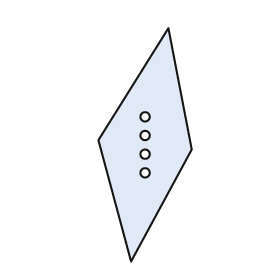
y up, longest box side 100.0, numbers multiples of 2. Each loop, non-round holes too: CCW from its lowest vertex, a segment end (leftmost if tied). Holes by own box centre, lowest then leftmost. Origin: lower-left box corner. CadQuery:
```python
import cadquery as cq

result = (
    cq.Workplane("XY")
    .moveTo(14.0, 0.0)
    .lineTo(40.0, 48.0)
    .lineTo(30.0, 100.0)
    .lineTo(0.0, 52.0)
    .close()
    .moveTo(20.0, 38.0)
    .circle(2.0)
    .moveTo(20.0, 46.0)
    .circle(2.0)
    .moveTo(20.0, 54.0)
    .circle(2.0)
    .moveTo(20.0, 62.0)
    .circle(2.0)
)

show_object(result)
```